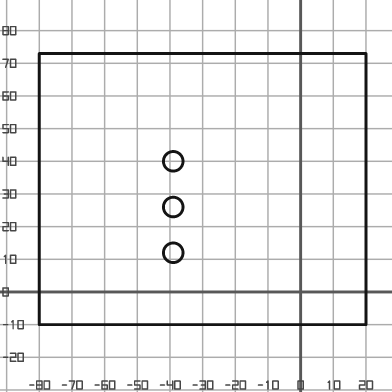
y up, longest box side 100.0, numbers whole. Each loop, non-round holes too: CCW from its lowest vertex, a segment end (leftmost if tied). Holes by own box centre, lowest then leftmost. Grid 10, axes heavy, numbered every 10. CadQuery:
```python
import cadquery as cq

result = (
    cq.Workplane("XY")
    .moveTo(-80.0, -10.0)
    .lineTo(20.0, -10.0)
    .lineTo(20.0, 73.0)
    .lineTo(-80.0, 73.0)
    .close()
    .moveTo(-39.0, 12.0)
    .circle(3.0)
    .moveTo(-39.0, 26.0)
    .circle(3.0)
    .moveTo(-39.0, 40.0)
    .circle(3.0)
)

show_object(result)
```